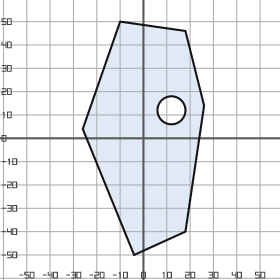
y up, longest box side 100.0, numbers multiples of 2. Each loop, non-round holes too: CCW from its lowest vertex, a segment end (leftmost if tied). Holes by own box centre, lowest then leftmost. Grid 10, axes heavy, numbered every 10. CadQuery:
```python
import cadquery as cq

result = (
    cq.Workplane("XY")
    .moveTo(-4.0, -50.0)
    .lineTo(18.0, -40.0)
    .lineTo(26.0, 14.0)
    .lineTo(18.0, 46.0)
    .lineTo(-10.0, 50.0)
    .lineTo(-26.0, 4.0)
    .close()
    .moveTo(12.0, 12.0)
    .circle(6.0)
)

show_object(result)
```